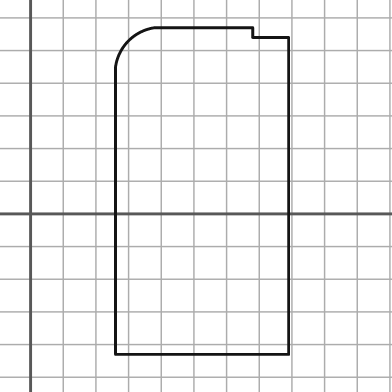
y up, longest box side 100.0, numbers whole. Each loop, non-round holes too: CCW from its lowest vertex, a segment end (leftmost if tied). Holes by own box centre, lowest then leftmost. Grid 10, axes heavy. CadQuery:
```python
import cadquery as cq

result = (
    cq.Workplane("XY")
    .moveTo(26.0, -43.0)
    .lineTo(79.0, -43.0)
    .lineTo(79.0, 54.0)
    .lineTo(68.0, 54.0)
    .lineTo(68.0, 57.0)
    .lineTo(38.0, 57.0)
    .threePointArc((30.0, 53.0), (26.0, 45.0))
    .close()
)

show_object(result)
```